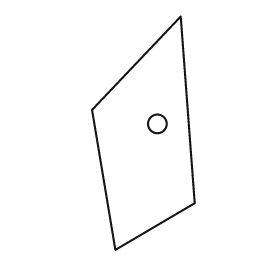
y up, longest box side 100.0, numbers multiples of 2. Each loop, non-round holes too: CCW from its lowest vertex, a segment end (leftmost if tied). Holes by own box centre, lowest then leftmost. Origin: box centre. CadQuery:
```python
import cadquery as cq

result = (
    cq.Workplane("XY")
    .moveTo(-12.0, -50.0)
    .lineTo(22.0, -30.0)
    .lineTo(16.0, 50.0)
    .lineTo(-22.0, 10.0)
    .close()
    .moveTo(6.0, 4.0)
    .circle(4.0)
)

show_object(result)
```